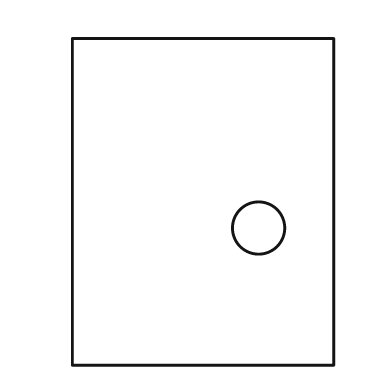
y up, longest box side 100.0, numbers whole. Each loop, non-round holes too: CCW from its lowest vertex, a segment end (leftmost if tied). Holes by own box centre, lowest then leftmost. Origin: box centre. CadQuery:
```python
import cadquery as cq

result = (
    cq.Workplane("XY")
    .moveTo(-40.0, -50.0)
    .lineTo(40.0, -50.0)
    .lineTo(40.0, 50.0)
    .lineTo(-40.0, 50.0)
    .close()
    .moveTo(17.0, -8.0)
    .circle(8.0)
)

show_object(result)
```